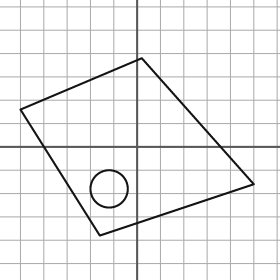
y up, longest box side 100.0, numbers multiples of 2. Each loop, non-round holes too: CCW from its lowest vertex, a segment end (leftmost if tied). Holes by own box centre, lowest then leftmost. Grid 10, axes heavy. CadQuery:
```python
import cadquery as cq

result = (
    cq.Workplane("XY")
    .moveTo(-16.0, -38.0)
    .lineTo(50.0, -16.0)
    .lineTo(2.0, 38.0)
    .lineTo(-50.0, 16.0)
    .close()
    .moveTo(-12.0, -18.0)
    .circle(8.0)
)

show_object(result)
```